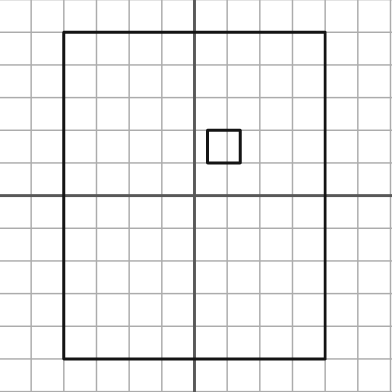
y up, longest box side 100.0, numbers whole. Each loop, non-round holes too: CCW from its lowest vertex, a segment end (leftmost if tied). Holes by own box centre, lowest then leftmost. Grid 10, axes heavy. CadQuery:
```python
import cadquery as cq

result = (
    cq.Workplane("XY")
    .moveTo(-40.0, -50.0)
    .lineTo(40.0, -50.0)
    .lineTo(40.0, 50.0)
    .lineTo(-40.0, 50.0)
    .close()
    .moveTo(4.0, 10.0)
    .lineTo(14.0, 10.0)
    .lineTo(14.0, 20.0)
    .lineTo(4.0, 20.0)
    .close()
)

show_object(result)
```